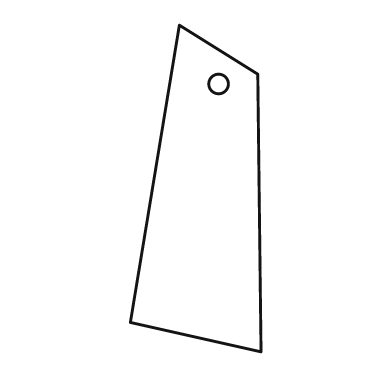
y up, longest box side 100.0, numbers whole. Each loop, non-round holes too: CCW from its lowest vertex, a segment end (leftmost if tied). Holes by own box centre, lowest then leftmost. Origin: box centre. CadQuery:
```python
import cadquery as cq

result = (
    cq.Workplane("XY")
    .moveTo(20.0, -50.0)
    .lineTo(19.0, 35.0)
    .lineTo(-5.0, 50.0)
    .lineTo(-20.0, -41.0)
    .close()
    .moveTo(7.0, 32.0)
    .circle(3.0)
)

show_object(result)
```